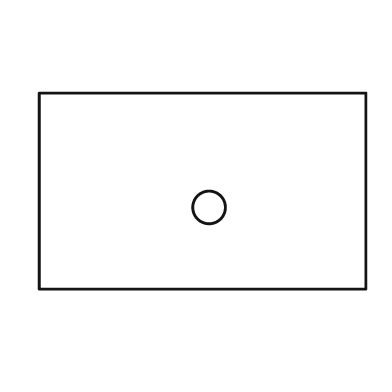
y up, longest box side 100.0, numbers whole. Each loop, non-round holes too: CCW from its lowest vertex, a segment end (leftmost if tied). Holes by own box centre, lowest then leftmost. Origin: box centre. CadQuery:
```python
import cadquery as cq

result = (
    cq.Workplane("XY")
    .moveTo(-50.0, -30.0)
    .lineTo(50.0, -30.0)
    .lineTo(50.0, 30.0)
    .lineTo(-50.0, 30.0)
    .close()
    .moveTo(2.0, -5.0)
    .circle(5.0)
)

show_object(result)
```